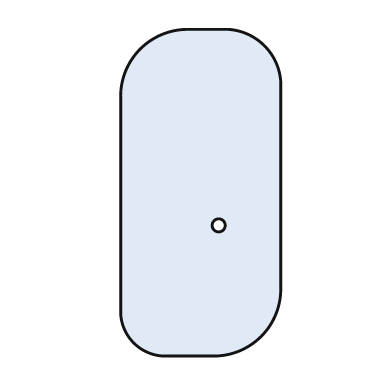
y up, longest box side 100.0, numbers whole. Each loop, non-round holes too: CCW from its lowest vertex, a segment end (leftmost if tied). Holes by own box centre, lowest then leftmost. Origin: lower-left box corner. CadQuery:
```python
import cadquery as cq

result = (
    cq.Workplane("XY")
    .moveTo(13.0, 0.0)
    .lineTo(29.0, 0.0)
    .threePointArc((43.0, 6.0), (49.0, 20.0))
    .lineTo(49.0, 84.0)
    .threePointArc((44.0, 95.0), (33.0, 100.0))
    .lineTo(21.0, 100.0)
    .threePointArc((6.0, 94.0), (0.0, 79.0))
    .lineTo(0.0, 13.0)
    .threePointArc((4.0, 4.0), (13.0, 0.0))
    .close()
    .moveTo(30.0, 40.0)
    .circle(2.0)
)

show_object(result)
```